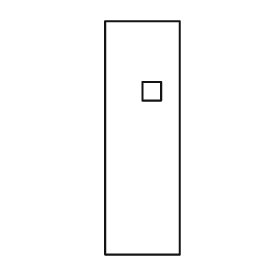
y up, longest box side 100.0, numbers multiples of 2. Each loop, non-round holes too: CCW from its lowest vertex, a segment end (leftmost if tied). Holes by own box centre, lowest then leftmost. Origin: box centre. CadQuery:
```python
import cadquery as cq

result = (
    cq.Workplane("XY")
    .moveTo(-16.0, -50.0)
    .lineTo(16.0, -50.0)
    .lineTo(16.0, 50.0)
    .lineTo(-16.0, 50.0)
    .close()
    .moveTo(0.0, 16.0)
    .lineTo(8.0, 16.0)
    .lineTo(8.0, 24.0)
    .lineTo(0.0, 24.0)
    .close()
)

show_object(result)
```